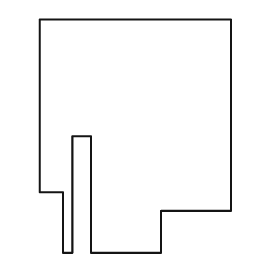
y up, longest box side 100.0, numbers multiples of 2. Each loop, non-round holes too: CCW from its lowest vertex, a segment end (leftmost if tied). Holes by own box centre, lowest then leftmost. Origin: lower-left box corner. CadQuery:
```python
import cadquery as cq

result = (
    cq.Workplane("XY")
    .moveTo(10.0, 0.0)
    .lineTo(14.0, 0.0)
    .lineTo(14.0, 50.0)
    .lineTo(22.0, 50.0)
    .lineTo(22.0, 0.0)
    .lineTo(52.0, 0.0)
    .lineTo(52.0, 18.0)
    .lineTo(82.0, 18.0)
    .lineTo(82.0, 100.0)
    .lineTo(0.0, 100.0)
    .lineTo(0.0, 26.0)
    .lineTo(10.0, 26.0)
    .close()
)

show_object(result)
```